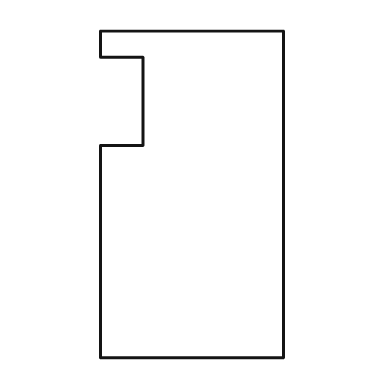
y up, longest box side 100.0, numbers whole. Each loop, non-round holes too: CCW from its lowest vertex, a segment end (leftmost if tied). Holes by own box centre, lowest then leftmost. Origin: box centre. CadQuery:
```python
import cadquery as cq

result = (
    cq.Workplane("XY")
    .moveTo(-28.0, -50.0)
    .lineTo(28.0, -50.0)
    .lineTo(28.0, 50.0)
    .lineTo(-28.0, 50.0)
    .lineTo(-28.0, 42.0)
    .lineTo(-15.0, 42.0)
    .lineTo(-15.0, 15.0)
    .lineTo(-28.0, 15.0)
    .close()
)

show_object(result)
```